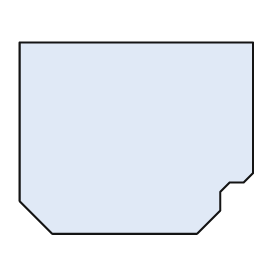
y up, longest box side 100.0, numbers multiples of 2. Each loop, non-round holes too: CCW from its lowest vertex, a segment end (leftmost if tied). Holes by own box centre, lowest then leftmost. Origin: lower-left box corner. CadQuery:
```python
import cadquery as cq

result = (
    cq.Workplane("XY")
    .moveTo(14.0, 0.0)
    .lineTo(76.0, 0.0)
    .lineTo(86.0, 10.0)
    .lineTo(86.0, 18.0)
    .lineTo(90.0, 22.0)
    .lineTo(96.0, 22.0)
    .lineTo(100.0, 26.0)
    .lineTo(100.0, 82.0)
    .lineTo(0.0, 82.0)
    .lineTo(0.0, 14.0)
    .close()
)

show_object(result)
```